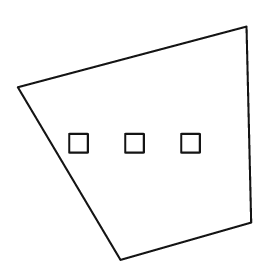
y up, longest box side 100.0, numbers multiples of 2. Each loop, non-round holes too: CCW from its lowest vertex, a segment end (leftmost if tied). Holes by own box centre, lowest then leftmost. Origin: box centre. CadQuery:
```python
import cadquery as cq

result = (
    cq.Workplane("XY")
    .moveTo(-6.0, -50.0)
    .lineTo(50.0, -34.0)
    .lineTo(48.0, 50.0)
    .lineTo(-50.0, 24.0)
    .close()
    .moveTo(-28.0, -4.0)
    .lineTo(-20.0, -4.0)
    .lineTo(-20.0, 4.0)
    .lineTo(-28.0, 4.0)
    .close()
    .moveTo(-4.0, -4.0)
    .lineTo(4.0, -4.0)
    .lineTo(4.0, 4.0)
    .lineTo(-4.0, 4.0)
    .close()
    .moveTo(20.0, -4.0)
    .lineTo(28.0, -4.0)
    .lineTo(28.0, 4.0)
    .lineTo(20.0, 4.0)
    .close()
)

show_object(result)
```